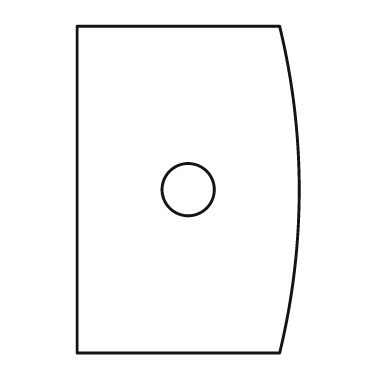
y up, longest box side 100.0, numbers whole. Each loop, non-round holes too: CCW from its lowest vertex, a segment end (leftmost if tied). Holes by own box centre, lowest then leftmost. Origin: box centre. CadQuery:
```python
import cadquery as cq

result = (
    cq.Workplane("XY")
    .moveTo(-34.0, -50.0)
    .lineTo(28.0, -50.0)
    .threePointArc((34.0, 0.0), (28.0, 50.0))
    .lineTo(-34.0, 50.0)
    .close()
    .moveTo(0.0, 0.0)
    .circle(8.0)
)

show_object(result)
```